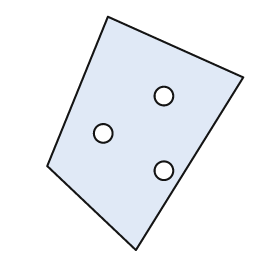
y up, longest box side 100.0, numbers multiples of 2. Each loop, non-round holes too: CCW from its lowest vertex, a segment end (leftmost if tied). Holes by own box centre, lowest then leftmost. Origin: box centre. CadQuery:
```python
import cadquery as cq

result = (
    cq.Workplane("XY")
    .moveTo(-4.0, -50.0)
    .lineTo(42.0, 24.0)
    .lineTo(-16.0, 50.0)
    .lineTo(-42.0, -14.0)
    .close()
    .moveTo(8.0, -16.0)
    .circle(4.0)
    .moveTo(-18.0, 0.0)
    .circle(4.0)
    .moveTo(8.0, 16.0)
    .circle(4.0)
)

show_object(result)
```